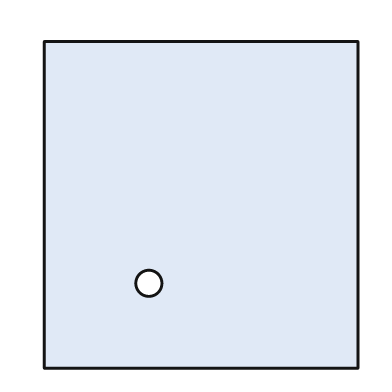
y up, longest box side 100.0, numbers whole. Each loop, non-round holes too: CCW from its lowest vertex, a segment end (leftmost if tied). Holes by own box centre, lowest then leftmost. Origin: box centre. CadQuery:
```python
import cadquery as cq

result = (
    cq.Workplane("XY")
    .moveTo(-48.0, -50.0)
    .lineTo(48.0, -50.0)
    .lineTo(48.0, 50.0)
    .lineTo(-48.0, 50.0)
    .close()
    .moveTo(-16.0, -24.0)
    .circle(4.0)
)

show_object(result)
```